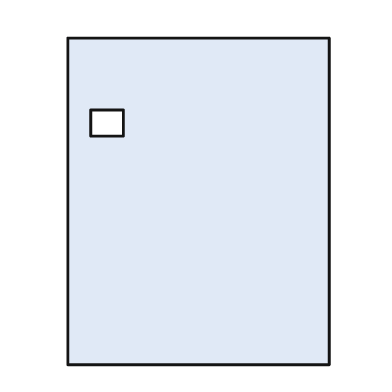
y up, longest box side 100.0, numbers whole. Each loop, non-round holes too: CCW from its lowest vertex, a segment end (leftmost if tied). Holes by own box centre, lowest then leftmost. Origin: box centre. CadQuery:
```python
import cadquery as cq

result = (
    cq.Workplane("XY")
    .moveTo(-40.0, -50.0)
    .lineTo(40.0, -50.0)
    .lineTo(40.0, 50.0)
    .lineTo(-40.0, 50.0)
    .close()
    .moveTo(-33.0, 20.0)
    .lineTo(-23.0, 20.0)
    .lineTo(-23.0, 28.0)
    .lineTo(-33.0, 28.0)
    .close()
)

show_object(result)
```